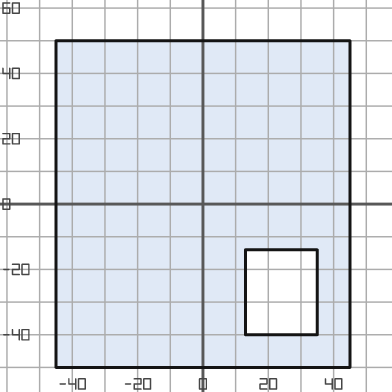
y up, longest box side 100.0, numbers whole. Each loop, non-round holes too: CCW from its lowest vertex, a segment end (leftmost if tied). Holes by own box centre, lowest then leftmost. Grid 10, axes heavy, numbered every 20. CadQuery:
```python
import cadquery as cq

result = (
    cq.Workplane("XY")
    .moveTo(-45.0, -50.0)
    .lineTo(45.0, -50.0)
    .lineTo(45.0, 50.0)
    .lineTo(-45.0, 50.0)
    .close()
    .moveTo(13.0, -40.0)
    .lineTo(35.0, -40.0)
    .lineTo(35.0, -14.0)
    .lineTo(13.0, -14.0)
    .close()
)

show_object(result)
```